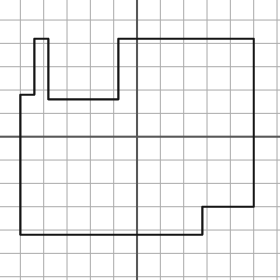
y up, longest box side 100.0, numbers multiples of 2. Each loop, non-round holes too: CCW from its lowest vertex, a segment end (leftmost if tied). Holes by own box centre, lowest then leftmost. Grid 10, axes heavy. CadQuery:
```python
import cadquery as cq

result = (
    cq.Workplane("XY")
    .moveTo(-50.0, -42.0)
    .lineTo(28.0, -42.0)
    .lineTo(28.0, -30.0)
    .lineTo(50.0, -30.0)
    .lineTo(50.0, 42.0)
    .lineTo(-8.0, 42.0)
    .lineTo(-8.0, 16.0)
    .lineTo(-38.0, 16.0)
    .lineTo(-38.0, 42.0)
    .lineTo(-44.0, 42.0)
    .lineTo(-44.0, 18.0)
    .lineTo(-50.0, 18.0)
    .close()
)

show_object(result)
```